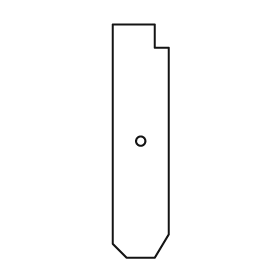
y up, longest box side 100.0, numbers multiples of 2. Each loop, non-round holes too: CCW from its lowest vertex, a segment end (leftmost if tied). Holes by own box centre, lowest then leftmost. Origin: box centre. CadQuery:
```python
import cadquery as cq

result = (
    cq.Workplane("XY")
    .moveTo(-6.0, -50.0)
    .lineTo(6.0, -50.0)
    .lineTo(12.0, -40.0)
    .lineTo(12.0, 40.0)
    .lineTo(6.0, 40.0)
    .lineTo(6.0, 50.0)
    .lineTo(-12.0, 50.0)
    .lineTo(-12.0, -44.0)
    .close()
    .moveTo(0.0, 0.0)
    .circle(2.0)
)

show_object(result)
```